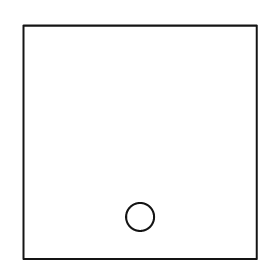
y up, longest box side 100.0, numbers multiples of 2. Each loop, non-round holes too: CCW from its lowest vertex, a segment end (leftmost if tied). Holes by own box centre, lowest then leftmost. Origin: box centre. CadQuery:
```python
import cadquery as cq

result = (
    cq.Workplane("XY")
    .moveTo(-50.0, -50.0)
    .lineTo(50.0, -50.0)
    .lineTo(50.0, 50.0)
    .lineTo(-50.0, 50.0)
    .close()
    .moveTo(0.0, -32.0)
    .circle(6.0)
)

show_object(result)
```